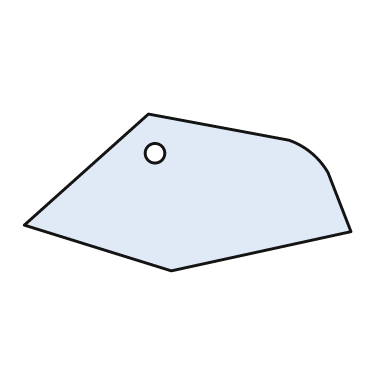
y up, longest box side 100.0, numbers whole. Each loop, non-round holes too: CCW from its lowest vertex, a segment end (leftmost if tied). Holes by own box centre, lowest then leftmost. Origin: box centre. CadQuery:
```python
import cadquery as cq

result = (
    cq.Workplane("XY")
    .moveTo(-5.0, -24.0)
    .lineTo(50.0, -12.0)
    .lineTo(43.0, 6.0)
    .threePointArc((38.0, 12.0), (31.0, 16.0))
    .lineTo(-12.0, 24.0)
    .lineTo(-50.0, -10.0)
    .close()
    .moveTo(-10.0, 12.0)
    .circle(3.0)
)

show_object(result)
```